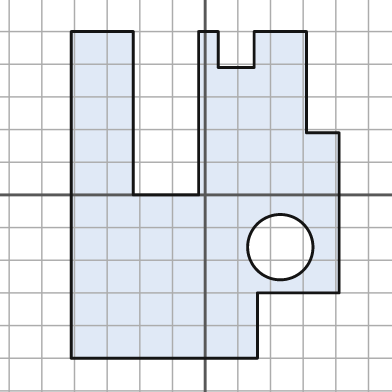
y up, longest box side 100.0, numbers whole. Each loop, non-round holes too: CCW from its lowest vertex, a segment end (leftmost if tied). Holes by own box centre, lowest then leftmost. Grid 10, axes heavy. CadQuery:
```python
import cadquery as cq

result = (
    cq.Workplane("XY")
    .moveTo(-41.0, -50.0)
    .lineTo(16.0, -50.0)
    .lineTo(16.0, -30.0)
    .lineTo(41.0, -30.0)
    .lineTo(41.0, 19.0)
    .lineTo(31.0, 19.0)
    .lineTo(31.0, 50.0)
    .lineTo(15.0, 50.0)
    .lineTo(15.0, 39.0)
    .lineTo(4.0, 39.0)
    .lineTo(4.0, 50.0)
    .lineTo(-2.0, 50.0)
    .lineTo(-2.0, 0.0)
    .lineTo(-22.0, 0.0)
    .lineTo(-22.0, 50.0)
    .lineTo(-41.0, 50.0)
    .close()
    .moveTo(23.0, -16.0)
    .circle(10.0)
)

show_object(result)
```